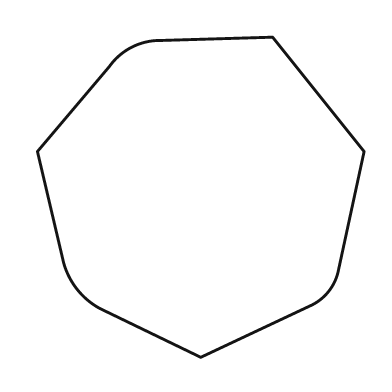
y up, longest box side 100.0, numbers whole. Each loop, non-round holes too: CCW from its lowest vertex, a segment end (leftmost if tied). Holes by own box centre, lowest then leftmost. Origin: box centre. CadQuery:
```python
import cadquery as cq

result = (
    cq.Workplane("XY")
    .moveTo(0.0, -49.0)
    .lineTo(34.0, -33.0)
    .threePointArc((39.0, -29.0), (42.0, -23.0))
    .lineTo(50.0, 14.0)
    .lineTo(22.0, 49.0)
    .lineTo(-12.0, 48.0)
    .threePointArc((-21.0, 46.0), (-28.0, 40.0))
    .lineTo(-50.0, 14.0)
    .lineTo(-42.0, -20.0)
    .threePointArc((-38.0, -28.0), (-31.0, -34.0))
    .close()
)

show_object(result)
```